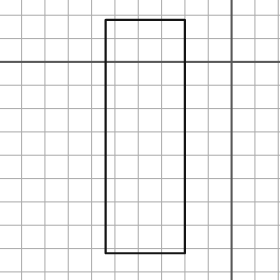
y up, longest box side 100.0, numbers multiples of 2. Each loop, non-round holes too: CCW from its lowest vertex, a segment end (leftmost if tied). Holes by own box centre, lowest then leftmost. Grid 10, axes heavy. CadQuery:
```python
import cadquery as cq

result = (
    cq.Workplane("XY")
    .moveTo(-54.0, -82.0)
    .lineTo(-20.0, -82.0)
    .lineTo(-20.0, 18.0)
    .lineTo(-54.0, 18.0)
    .close()
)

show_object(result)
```